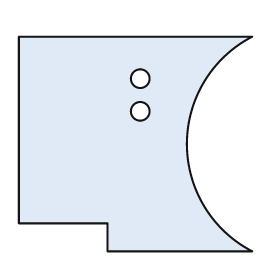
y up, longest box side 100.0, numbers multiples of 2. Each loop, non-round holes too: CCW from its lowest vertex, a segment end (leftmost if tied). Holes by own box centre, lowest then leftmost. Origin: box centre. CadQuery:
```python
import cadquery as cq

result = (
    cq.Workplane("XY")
    .moveTo(-12.0, -46.0)
    .lineTo(50.0, -46.0)
    .threePointArc((22.0, 0.0), (50.0, 46.0))
    .lineTo(-50.0, 46.0)
    .lineTo(-50.0, -34.0)
    .lineTo(-12.0, -34.0)
    .close()
    .moveTo(2.0, 14.0)
    .circle(4.0)
    .moveTo(2.0, 28.0)
    .circle(4.0)
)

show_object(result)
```